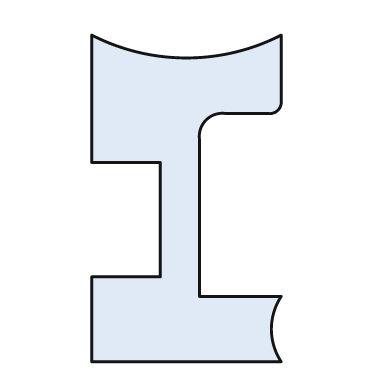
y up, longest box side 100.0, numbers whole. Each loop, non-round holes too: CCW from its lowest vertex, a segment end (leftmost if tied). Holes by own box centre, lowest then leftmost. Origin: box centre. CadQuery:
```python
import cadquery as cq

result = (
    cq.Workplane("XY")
    .moveTo(-29.0, -50.0)
    .lineTo(29.0, -50.0)
    .threePointArc((26.0, -40.0), (29.0, -30.0))
    .lineTo(4.0, -30.0)
    .lineTo(4.0, 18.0)
    .threePointArc((6.0, 24.0), (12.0, 26.0))
    .lineTo(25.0, 26.0)
    .threePointArc((28.0, 27.0), (29.0, 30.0))
    .lineTo(29.0, 50.0)
    .threePointArc((0.0, 43.0), (-29.0, 50.0))
    .lineTo(-29.0, 11.0)
    .lineTo(-8.0, 11.0)
    .lineTo(-8.0, -24.0)
    .lineTo(-29.0, -24.0)
    .close()
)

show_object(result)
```